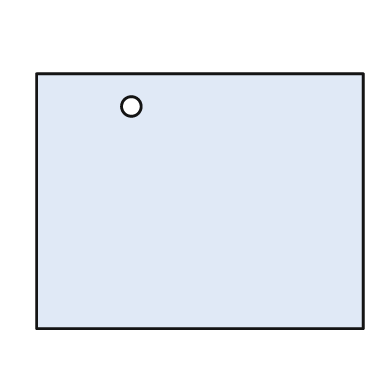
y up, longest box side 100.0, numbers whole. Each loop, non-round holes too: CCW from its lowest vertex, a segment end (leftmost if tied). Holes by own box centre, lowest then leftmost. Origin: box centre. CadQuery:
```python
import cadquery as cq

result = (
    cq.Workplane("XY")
    .moveTo(-50.0, -39.0)
    .lineTo(50.0, -39.0)
    .lineTo(50.0, 39.0)
    .lineTo(-50.0, 39.0)
    .close()
    .moveTo(-21.0, 29.0)
    .circle(3.0)
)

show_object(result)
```